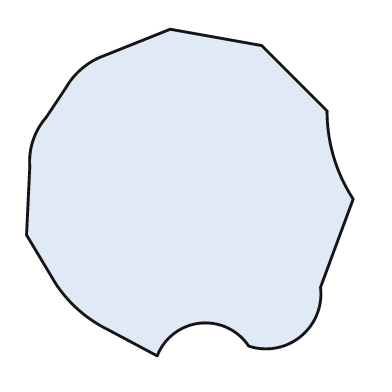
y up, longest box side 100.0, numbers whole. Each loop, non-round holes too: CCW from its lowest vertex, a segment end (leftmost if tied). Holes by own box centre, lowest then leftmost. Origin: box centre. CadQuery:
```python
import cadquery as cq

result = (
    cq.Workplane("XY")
    .moveTo(-10.0, -50.0)
    .threePointArc((3.0, -40.0), (18.0, -47.0))
    .threePointArc((34.0, -44.0), (40.0, -29.0))
    .lineTo(50.0, -2.0)
    .threePointArc((44.0, 11.0), (42.0, 25.0))
    .lineTo(22.0, 45.0)
    .lineTo(-6.0, 50.0)
    .lineTo(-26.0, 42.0)
    .threePointArc((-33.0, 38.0), (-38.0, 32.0))
    .lineTo(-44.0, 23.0)
    .threePointArc((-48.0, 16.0), (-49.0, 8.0))
    .lineTo(-50.0, -13.0)
    .lineTo(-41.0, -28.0)
    .threePointArc((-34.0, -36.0), (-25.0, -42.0))
    .close()
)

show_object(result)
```